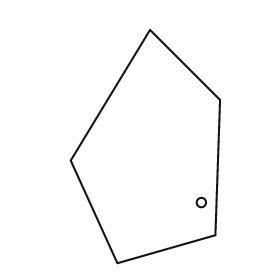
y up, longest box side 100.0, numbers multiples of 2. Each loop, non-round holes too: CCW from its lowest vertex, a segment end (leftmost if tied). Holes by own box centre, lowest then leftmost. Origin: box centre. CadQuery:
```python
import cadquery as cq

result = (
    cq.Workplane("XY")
    .moveTo(-12.0, -50.0)
    .lineTo(30.0, -38.0)
    .lineTo(32.0, 20.0)
    .lineTo(2.0, 50.0)
    .lineTo(-32.0, -6.0)
    .close()
    .moveTo(24.0, -24.0)
    .circle(2.0)
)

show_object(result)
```